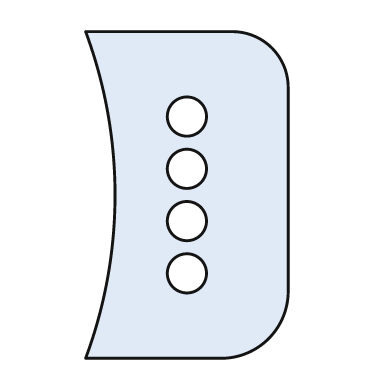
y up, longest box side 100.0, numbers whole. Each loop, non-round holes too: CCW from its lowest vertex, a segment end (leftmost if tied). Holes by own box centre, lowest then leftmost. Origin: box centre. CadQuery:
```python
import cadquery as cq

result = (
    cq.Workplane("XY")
    .moveTo(-31.0, -50.0)
    .lineTo(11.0, -50.0)
    .threePointArc((25.0, -44.0), (31.0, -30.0))
    .lineTo(31.0, 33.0)
    .threePointArc((26.0, 45.0), (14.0, 50.0))
    .lineTo(-31.0, 50.0)
    .threePointArc((-22.0, 0.0), (-31.0, -50.0))
    .close()
    .moveTo(0.0, -24.0)
    .circle(6.0)
    .moveTo(0.0, -8.0)
    .circle(6.0)
    .moveTo(0.0, 8.0)
    .circle(6.0)
    .moveTo(0.0, 24.0)
    .circle(6.0)
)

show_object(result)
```